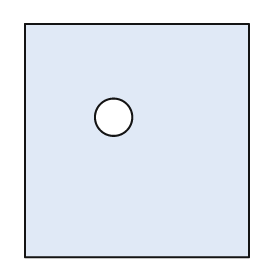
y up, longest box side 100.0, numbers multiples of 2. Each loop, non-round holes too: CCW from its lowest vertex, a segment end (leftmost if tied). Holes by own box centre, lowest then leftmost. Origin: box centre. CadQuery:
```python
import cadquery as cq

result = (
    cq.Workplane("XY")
    .moveTo(-48.0, -50.0)
    .lineTo(48.0, -50.0)
    .lineTo(48.0, 50.0)
    .lineTo(-48.0, 50.0)
    .close()
    .moveTo(-10.0, 10.0)
    .circle(8.0)
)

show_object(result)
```